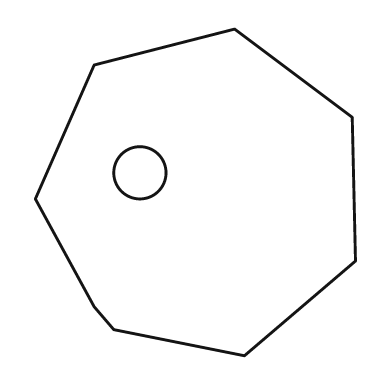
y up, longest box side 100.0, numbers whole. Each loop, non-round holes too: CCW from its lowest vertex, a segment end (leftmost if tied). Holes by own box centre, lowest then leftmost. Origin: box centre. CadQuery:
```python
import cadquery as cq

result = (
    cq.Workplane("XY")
    .moveTo(15.0, -50.0)
    .lineTo(49.0, -21.0)
    .lineTo(48.0, 23.0)
    .lineTo(12.0, 50.0)
    .lineTo(-31.0, 39.0)
    .lineTo(-49.0, -2.0)
    .lineTo(-31.0, -35.0)
    .lineTo(-25.0, -42.0)
    .close()
    .moveTo(-17.0, 6.0)
    .circle(8.0)
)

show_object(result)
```